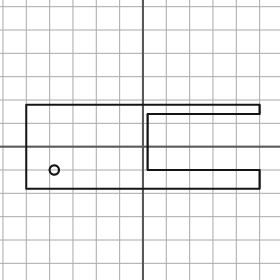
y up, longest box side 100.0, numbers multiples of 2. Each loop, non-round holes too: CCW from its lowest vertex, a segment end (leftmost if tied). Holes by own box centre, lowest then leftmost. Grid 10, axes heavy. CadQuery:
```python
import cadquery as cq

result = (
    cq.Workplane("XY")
    .moveTo(-50.0, -18.0)
    .lineTo(50.0, -18.0)
    .lineTo(50.0, -10.0)
    .lineTo(2.0, -10.0)
    .lineTo(2.0, 14.0)
    .lineTo(50.0, 14.0)
    .lineTo(50.0, 18.0)
    .lineTo(-50.0, 18.0)
    .close()
    .moveTo(-38.0, -10.0)
    .circle(2.0)
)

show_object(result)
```